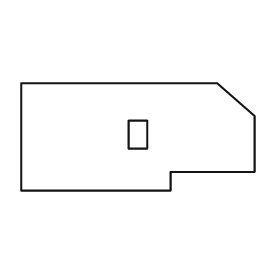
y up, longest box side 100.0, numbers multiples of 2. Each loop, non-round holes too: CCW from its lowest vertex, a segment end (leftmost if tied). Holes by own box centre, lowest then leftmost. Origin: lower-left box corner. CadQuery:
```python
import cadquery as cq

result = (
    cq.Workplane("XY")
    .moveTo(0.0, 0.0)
    .lineTo(64.0, 0.0)
    .lineTo(64.0, 8.0)
    .lineTo(100.0, 8.0)
    .lineTo(100.0, 32.0)
    .lineTo(84.0, 46.0)
    .lineTo(0.0, 46.0)
    .close()
    .moveTo(46.0, 18.0)
    .lineTo(54.0, 18.0)
    .lineTo(54.0, 30.0)
    .lineTo(46.0, 30.0)
    .close()
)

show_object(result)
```